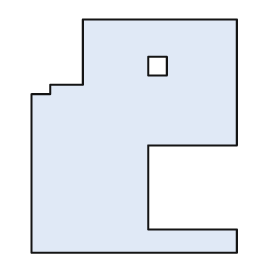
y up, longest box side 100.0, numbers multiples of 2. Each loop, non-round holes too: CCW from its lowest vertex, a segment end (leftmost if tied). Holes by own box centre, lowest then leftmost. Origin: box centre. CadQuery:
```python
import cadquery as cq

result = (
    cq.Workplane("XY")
    .moveTo(-44.0, -50.0)
    .lineTo(44.0, -50.0)
    .lineTo(44.0, -40.0)
    .lineTo(6.0, -40.0)
    .lineTo(6.0, -4.0)
    .lineTo(44.0, -4.0)
    .lineTo(44.0, 50.0)
    .lineTo(-22.0, 50.0)
    .lineTo(-22.0, 22.0)
    .lineTo(-36.0, 22.0)
    .lineTo(-36.0, 18.0)
    .lineTo(-44.0, 18.0)
    .close()
    .moveTo(6.0, 26.0)
    .lineTo(14.0, 26.0)
    .lineTo(14.0, 34.0)
    .lineTo(6.0, 34.0)
    .close()
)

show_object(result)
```